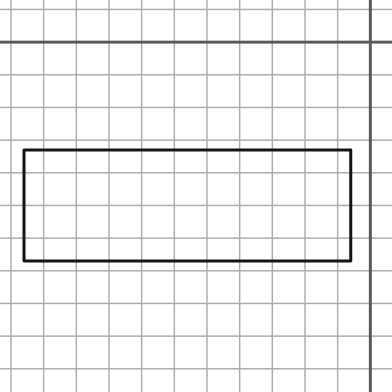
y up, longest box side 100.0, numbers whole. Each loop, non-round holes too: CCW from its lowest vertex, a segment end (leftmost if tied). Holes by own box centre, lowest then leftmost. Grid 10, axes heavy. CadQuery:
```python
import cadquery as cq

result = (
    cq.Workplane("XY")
    .moveTo(-106.0, -67.0)
    .lineTo(-6.0, -67.0)
    .lineTo(-6.0, -33.0)
    .lineTo(-106.0, -33.0)
    .close()
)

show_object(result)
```